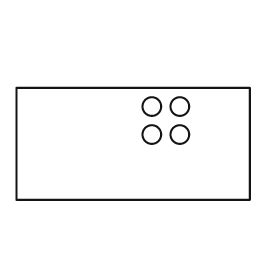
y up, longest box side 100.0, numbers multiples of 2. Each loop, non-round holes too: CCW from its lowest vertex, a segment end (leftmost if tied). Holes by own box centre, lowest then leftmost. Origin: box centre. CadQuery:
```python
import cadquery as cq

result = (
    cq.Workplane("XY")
    .moveTo(-50.0, -24.0)
    .lineTo(50.0, -24.0)
    .lineTo(50.0, 24.0)
    .lineTo(-50.0, 24.0)
    .close()
    .moveTo(8.0, 4.0)
    .circle(4.0)
    .moveTo(20.0, 4.0)
    .circle(4.0)
    .moveTo(8.0, 16.0)
    .circle(4.0)
    .moveTo(20.0, 16.0)
    .circle(4.0)
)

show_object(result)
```